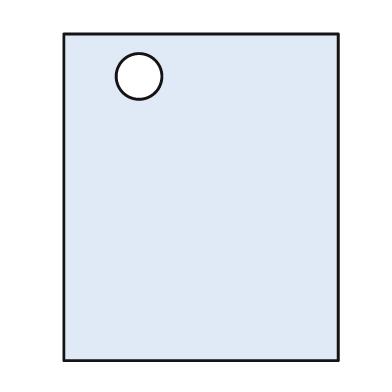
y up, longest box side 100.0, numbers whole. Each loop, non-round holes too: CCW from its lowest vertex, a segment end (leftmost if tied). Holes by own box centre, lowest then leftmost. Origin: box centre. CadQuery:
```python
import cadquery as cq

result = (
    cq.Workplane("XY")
    .moveTo(-42.0, -50.0)
    .lineTo(42.0, -50.0)
    .lineTo(42.0, 50.0)
    .lineTo(-42.0, 50.0)
    .close()
    .moveTo(-19.0, 37.0)
    .circle(7.0)
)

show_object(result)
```